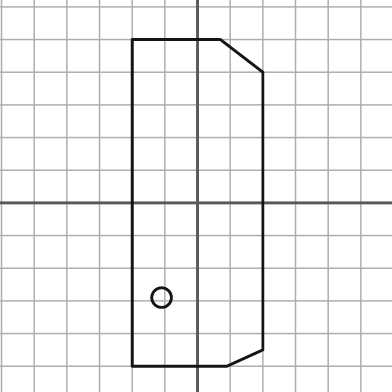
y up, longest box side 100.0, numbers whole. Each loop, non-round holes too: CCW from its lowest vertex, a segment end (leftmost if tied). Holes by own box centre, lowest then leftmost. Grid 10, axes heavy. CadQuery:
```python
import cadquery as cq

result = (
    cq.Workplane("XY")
    .moveTo(-20.0, -50.0)
    .lineTo(9.0, -50.0)
    .lineTo(20.0, -45.0)
    .lineTo(20.0, 40.0)
    .lineTo(7.0, 50.0)
    .lineTo(-20.0, 50.0)
    .close()
    .moveTo(-11.0, -29.0)
    .circle(3.0)
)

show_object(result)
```